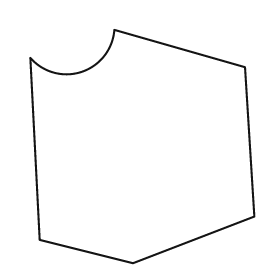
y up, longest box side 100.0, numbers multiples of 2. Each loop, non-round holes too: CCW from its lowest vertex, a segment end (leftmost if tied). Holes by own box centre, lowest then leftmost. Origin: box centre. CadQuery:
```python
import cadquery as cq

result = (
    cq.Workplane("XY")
    .moveTo(-4.0, -50.0)
    .lineTo(48.0, -30.0)
    .lineTo(44.0, 34.0)
    .lineTo(-12.0, 50.0)
    .threePointArc((-26.0, 32.0), (-48.0, 38.0))
    .lineTo(-44.0, -40.0)
    .close()
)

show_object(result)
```